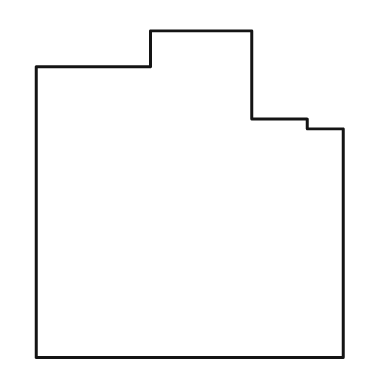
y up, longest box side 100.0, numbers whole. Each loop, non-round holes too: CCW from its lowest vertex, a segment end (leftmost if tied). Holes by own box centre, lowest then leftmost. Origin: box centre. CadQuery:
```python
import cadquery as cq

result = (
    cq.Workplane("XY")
    .moveTo(-47.0, -50.0)
    .lineTo(47.0, -50.0)
    .lineTo(47.0, 20.0)
    .lineTo(36.0, 20.0)
    .lineTo(36.0, 23.0)
    .lineTo(19.0, 23.0)
    .lineTo(19.0, 50.0)
    .lineTo(-12.0, 50.0)
    .lineTo(-12.0, 39.0)
    .lineTo(-47.0, 39.0)
    .close()
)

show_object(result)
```